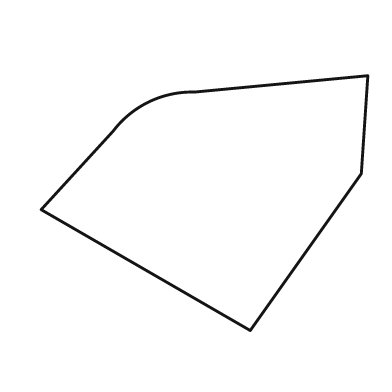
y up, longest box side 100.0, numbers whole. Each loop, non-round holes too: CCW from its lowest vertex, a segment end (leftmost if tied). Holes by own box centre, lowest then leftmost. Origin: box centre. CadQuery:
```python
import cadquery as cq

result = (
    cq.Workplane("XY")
    .moveTo(14.0, -39.0)
    .lineTo(48.0, 9.0)
    .lineTo(50.0, 39.0)
    .lineTo(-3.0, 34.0)
    .threePointArc((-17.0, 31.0), (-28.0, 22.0))
    .lineTo(-50.0, -2.0)
    .close()
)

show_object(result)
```